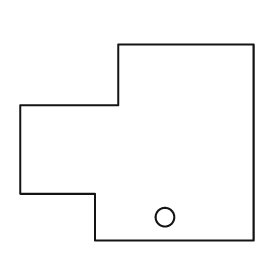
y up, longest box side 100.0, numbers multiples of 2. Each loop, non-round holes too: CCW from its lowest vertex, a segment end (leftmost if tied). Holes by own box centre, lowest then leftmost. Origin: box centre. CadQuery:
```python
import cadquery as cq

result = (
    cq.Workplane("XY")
    .moveTo(-18.0, -42.0)
    .lineTo(50.0, -42.0)
    .lineTo(50.0, 42.0)
    .lineTo(-8.0, 42.0)
    .lineTo(-8.0, 16.0)
    .lineTo(-50.0, 16.0)
    .lineTo(-50.0, -22.0)
    .lineTo(-18.0, -22.0)
    .close()
    .moveTo(12.0, -32.0)
    .circle(4.0)
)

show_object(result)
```